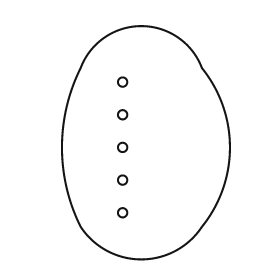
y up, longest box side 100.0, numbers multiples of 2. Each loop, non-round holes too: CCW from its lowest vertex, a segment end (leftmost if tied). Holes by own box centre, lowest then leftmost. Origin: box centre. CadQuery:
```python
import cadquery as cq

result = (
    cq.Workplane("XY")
    .moveTo(-28.0, -36.0)
    .threePointArc((-2.0, -50.0), (24.0, -36.0))
    .threePointArc((36.0, -2.0), (24.0, 32.0))
    .threePointArc((-2.0, 50.0), (-28.0, 32.0))
    .threePointArc((-36.0, -2.0), (-28.0, -36.0))
    .close()
    .moveTo(-10.0, -30.0)
    .circle(2.0)
    .moveTo(-10.0, -16.0)
    .circle(2.0)
    .moveTo(-10.0, -2.0)
    .circle(2.0)
    .moveTo(-10.0, 12.0)
    .circle(2.0)
    .moveTo(-10.0, 26.0)
    .circle(2.0)
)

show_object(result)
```